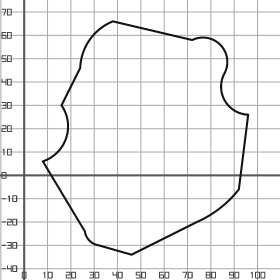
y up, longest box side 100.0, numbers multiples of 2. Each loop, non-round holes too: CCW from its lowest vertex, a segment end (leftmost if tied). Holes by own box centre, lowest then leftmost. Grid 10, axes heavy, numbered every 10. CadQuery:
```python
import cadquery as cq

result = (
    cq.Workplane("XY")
    .moveTo(46.0, -34.0)
    .lineTo(74.0, -20.0)
    .threePointArc((84.0, -14.0), (92.0, -6.0))
    .lineTo(96.0, 26.0)
    .threePointArc((86.0, 32.0), (86.0, 44.0))
    .threePointArc((84.0, 56.0), (72.0, 58.0))
    .lineTo(38.0, 66.0)
    .threePointArc((28.0, 58.0), (24.0, 46.0))
    .lineTo(16.0, 30.0)
    .threePointArc((18.0, 16.0), (8.0, 6.0))
    .lineTo(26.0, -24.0)
    .threePointArc((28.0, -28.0), (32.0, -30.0))
    .close()
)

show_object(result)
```